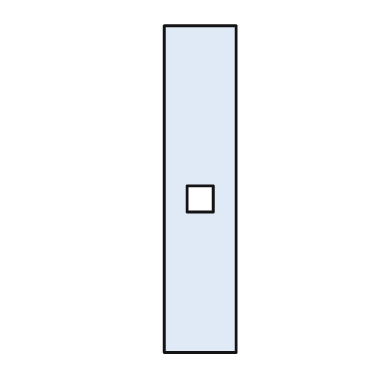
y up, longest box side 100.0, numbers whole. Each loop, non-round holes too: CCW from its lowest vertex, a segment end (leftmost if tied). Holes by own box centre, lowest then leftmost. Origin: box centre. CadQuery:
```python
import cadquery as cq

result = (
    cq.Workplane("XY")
    .moveTo(-11.0, -50.0)
    .lineTo(11.0, -50.0)
    .lineTo(11.0, 50.0)
    .lineTo(-11.0, 50.0)
    .close()
    .moveTo(-4.0, -7.0)
    .lineTo(4.0, -7.0)
    .lineTo(4.0, 1.0)
    .lineTo(-4.0, 1.0)
    .close()
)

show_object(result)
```